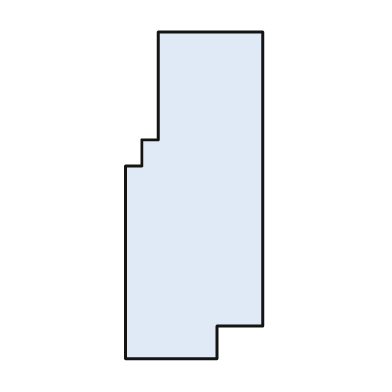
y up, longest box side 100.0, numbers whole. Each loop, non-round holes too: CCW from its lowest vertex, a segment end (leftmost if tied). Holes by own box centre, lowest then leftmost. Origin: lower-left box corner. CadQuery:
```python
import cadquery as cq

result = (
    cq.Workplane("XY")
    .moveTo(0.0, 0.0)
    .lineTo(28.0, 0.0)
    .lineTo(28.0, 10.0)
    .lineTo(42.0, 10.0)
    .lineTo(42.0, 100.0)
    .lineTo(10.0, 100.0)
    .lineTo(10.0, 67.0)
    .lineTo(5.0, 67.0)
    .lineTo(5.0, 59.0)
    .lineTo(0.0, 59.0)
    .close()
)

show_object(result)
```